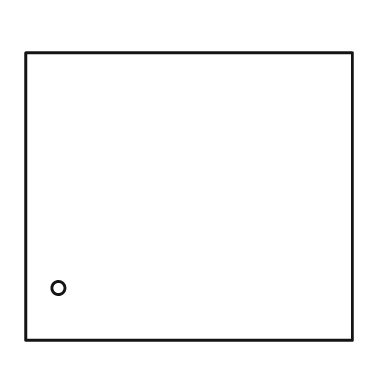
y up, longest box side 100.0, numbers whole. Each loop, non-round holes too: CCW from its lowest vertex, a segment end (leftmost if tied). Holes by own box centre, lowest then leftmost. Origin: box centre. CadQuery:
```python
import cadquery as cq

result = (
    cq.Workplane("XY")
    .moveTo(-50.0, -44.0)
    .lineTo(50.0, -44.0)
    .lineTo(50.0, 44.0)
    .lineTo(-50.0, 44.0)
    .close()
    .moveTo(-40.0, -28.0)
    .circle(2.0)
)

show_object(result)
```